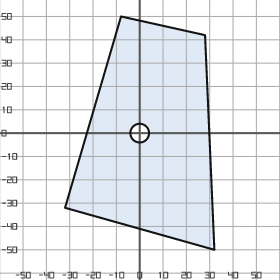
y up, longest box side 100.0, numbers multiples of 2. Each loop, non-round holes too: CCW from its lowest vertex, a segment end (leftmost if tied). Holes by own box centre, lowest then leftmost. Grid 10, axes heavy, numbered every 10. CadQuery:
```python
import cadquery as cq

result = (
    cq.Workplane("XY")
    .moveTo(32.0, -50.0)
    .lineTo(28.0, 42.0)
    .lineTo(-8.0, 50.0)
    .lineTo(-32.0, -32.0)
    .close()
    .moveTo(0.0, 0.0)
    .circle(4.0)
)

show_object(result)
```